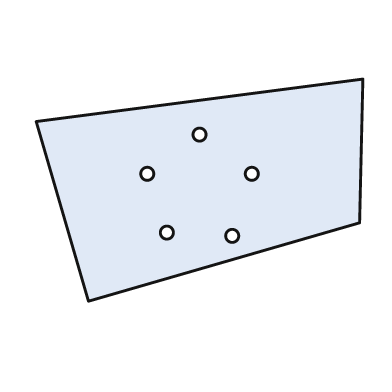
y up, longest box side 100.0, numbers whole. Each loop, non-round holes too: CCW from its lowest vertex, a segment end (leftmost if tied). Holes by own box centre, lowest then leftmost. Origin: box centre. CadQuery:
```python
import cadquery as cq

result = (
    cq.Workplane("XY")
    .moveTo(-34.0, -34.0)
    .lineTo(49.0, -10.0)
    .lineTo(50.0, 34.0)
    .lineTo(-50.0, 21.0)
    .close()
    .moveTo(10.0, -14.0)
    .circle(2.0)
    .moveTo(-10.0, -13.0)
    .circle(2.0)
    .moveTo(-16.0, 5.0)
    .circle(2.0)
    .moveTo(16.0, 5.0)
    .circle(2.0)
    .moveTo(0.0, 17.0)
    .circle(2.0)
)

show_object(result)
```